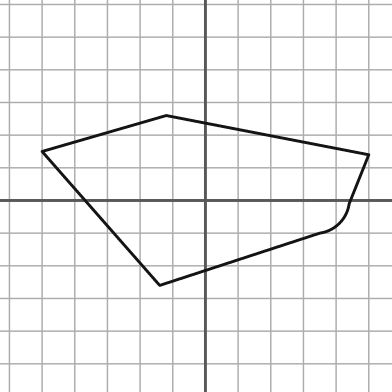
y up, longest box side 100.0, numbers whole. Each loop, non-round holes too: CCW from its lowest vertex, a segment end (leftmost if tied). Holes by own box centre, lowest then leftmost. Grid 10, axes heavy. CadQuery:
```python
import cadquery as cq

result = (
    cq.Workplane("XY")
    .moveTo(-14.0, -26.0)
    .lineTo(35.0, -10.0)
    .threePointArc((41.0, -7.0), (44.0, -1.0))
    .lineTo(50.0, 14.0)
    .lineTo(-12.0, 26.0)
    .lineTo(-50.0, 15.0)
    .close()
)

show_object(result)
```